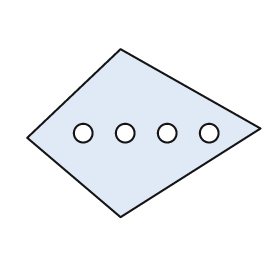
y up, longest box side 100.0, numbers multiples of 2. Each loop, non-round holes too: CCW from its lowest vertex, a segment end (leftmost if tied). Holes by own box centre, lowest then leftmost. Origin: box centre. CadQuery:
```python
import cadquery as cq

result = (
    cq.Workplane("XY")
    .moveTo(-10.0, -36.0)
    .lineTo(50.0, 2.0)
    .lineTo(-10.0, 36.0)
    .lineTo(-50.0, -2.0)
    .close()
    .moveTo(-26.0, 0.0)
    .circle(4.0)
    .moveTo(-8.0, 0.0)
    .circle(4.0)
    .moveTo(10.0, 0.0)
    .circle(4.0)
    .moveTo(28.0, 0.0)
    .circle(4.0)
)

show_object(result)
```